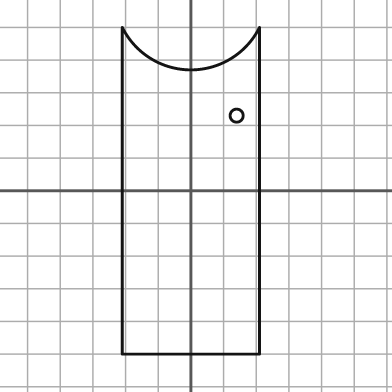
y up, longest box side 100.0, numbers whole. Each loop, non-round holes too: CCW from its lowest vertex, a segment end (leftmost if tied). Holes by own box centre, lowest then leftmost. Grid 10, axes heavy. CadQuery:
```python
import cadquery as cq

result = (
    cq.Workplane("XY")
    .moveTo(-21.0, -50.0)
    .lineTo(21.0, -50.0)
    .lineTo(21.0, 50.0)
    .threePointArc((0.0, 37.0), (-21.0, 50.0))
    .close()
    .moveTo(14.0, 23.0)
    .circle(2.0)
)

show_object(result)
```